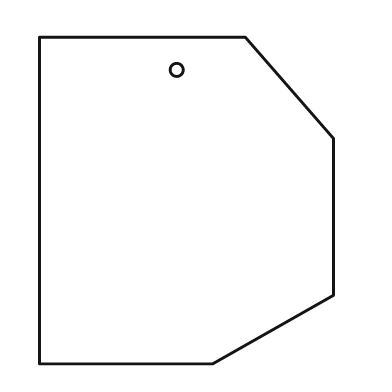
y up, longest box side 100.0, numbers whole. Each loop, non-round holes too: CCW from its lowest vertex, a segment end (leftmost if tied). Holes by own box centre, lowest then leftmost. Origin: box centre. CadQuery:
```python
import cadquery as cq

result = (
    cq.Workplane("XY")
    .moveTo(-45.0, -50.0)
    .lineTo(8.0, -50.0)
    .lineTo(45.0, -29.0)
    .lineTo(45.0, 19.0)
    .lineTo(18.0, 50.0)
    .lineTo(-45.0, 50.0)
    .close()
    .moveTo(-3.0, 40.0)
    .circle(2.0)
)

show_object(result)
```